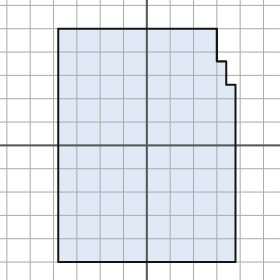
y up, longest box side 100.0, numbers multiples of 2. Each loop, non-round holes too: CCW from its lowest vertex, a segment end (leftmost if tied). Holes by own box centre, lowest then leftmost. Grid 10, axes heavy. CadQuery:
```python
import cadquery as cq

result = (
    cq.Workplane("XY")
    .moveTo(-38.0, -50.0)
    .lineTo(38.0, -50.0)
    .lineTo(38.0, 26.0)
    .lineTo(34.0, 26.0)
    .lineTo(34.0, 36.0)
    .lineTo(30.0, 36.0)
    .lineTo(30.0, 50.0)
    .lineTo(-38.0, 50.0)
    .close()
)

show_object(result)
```